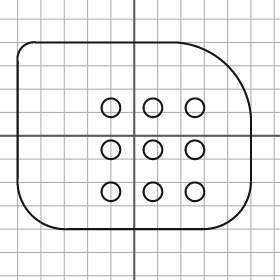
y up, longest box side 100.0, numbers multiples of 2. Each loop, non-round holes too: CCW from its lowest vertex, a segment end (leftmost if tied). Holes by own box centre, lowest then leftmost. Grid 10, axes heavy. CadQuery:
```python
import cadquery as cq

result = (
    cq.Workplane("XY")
    .moveTo(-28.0, -40.0)
    .lineTo(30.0, -40.0)
    .threePointArc((44.0, -34.0), (50.0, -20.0))
    .lineTo(50.0, 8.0)
    .threePointArc((40.0, 30.0), (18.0, 40.0))
    .lineTo(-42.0, 40.0)
    .threePointArc((-48.0, 38.0), (-50.0, 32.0))
    .lineTo(-50.0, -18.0)
    .threePointArc((-44.0, -34.0), (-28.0, -40.0))
    .close()
    .moveTo(-10.0, -24.0)
    .circle(4.0)
    .moveTo(8.0, -24.0)
    .circle(4.0)
    .moveTo(26.0, -24.0)
    .circle(4.0)
    .moveTo(-10.0, -6.0)
    .circle(4.0)
    .moveTo(8.0, -6.0)
    .circle(4.0)
    .moveTo(26.0, -6.0)
    .circle(4.0)
    .moveTo(-10.0, 12.0)
    .circle(4.0)
    .moveTo(8.0, 12.0)
    .circle(4.0)
    .moveTo(26.0, 12.0)
    .circle(4.0)
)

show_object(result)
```